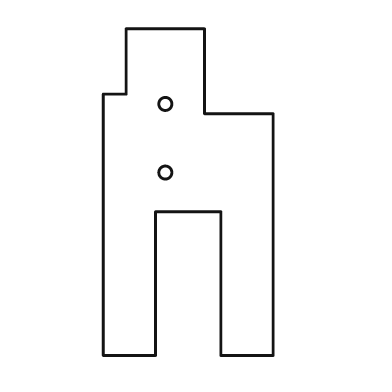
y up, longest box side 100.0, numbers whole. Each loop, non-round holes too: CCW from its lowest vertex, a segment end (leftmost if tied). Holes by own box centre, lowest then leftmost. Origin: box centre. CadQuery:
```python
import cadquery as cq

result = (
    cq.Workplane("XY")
    .moveTo(-26.0, -50.0)
    .lineTo(-10.0, -50.0)
    .lineTo(-10.0, -6.0)
    .lineTo(10.0, -6.0)
    .lineTo(10.0, -50.0)
    .lineTo(26.0, -50.0)
    .lineTo(26.0, 24.0)
    .lineTo(5.0, 24.0)
    .lineTo(5.0, 50.0)
    .lineTo(-19.0, 50.0)
    .lineTo(-19.0, 30.0)
    .lineTo(-26.0, 30.0)
    .close()
    .moveTo(-7.0, 6.0)
    .circle(2.0)
    .moveTo(-7.0, 27.0)
    .circle(2.0)
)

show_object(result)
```